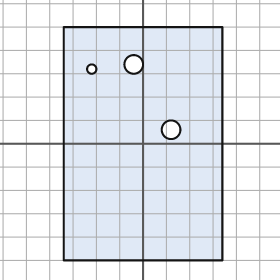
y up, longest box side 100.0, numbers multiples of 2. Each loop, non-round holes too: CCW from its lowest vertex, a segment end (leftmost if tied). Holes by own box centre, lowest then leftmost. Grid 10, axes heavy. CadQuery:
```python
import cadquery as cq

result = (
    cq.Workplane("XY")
    .moveTo(-34.0, -50.0)
    .lineTo(34.0, -50.0)
    .lineTo(34.0, 50.0)
    .lineTo(-34.0, 50.0)
    .close()
    .moveTo(12.0, 6.0)
    .circle(4.0)
    .moveTo(-22.0, 32.0)
    .circle(2.0)
    .moveTo(-4.0, 34.0)
    .circle(4.0)
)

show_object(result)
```